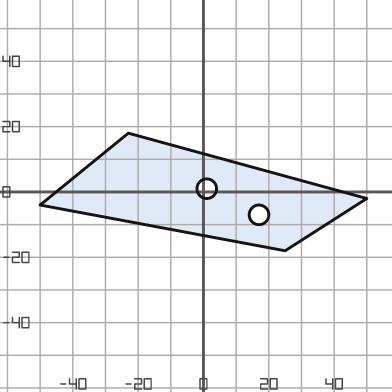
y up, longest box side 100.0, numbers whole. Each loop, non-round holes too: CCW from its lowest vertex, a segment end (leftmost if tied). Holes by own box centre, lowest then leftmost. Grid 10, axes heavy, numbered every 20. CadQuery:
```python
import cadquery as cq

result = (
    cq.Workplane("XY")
    .moveTo(25.0, -18.0)
    .lineTo(50.0, -2.0)
    .lineTo(-23.0, 18.0)
    .lineTo(-50.0, -4.0)
    .close()
    .moveTo(17.0, -7.0)
    .circle(3.0)
    .moveTo(1.0, 1.0)
    .circle(3.0)
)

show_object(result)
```